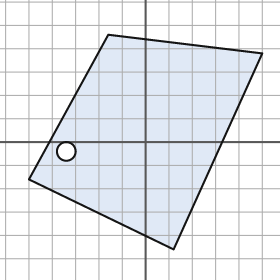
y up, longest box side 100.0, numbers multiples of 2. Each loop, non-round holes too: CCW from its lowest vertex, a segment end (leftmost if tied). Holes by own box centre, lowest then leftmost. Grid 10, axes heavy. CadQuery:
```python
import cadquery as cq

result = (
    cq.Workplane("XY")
    .moveTo(12.0, -46.0)
    .lineTo(50.0, 38.0)
    .lineTo(-16.0, 46.0)
    .lineTo(-50.0, -16.0)
    .close()
    .moveTo(-34.0, -4.0)
    .circle(4.0)
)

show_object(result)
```